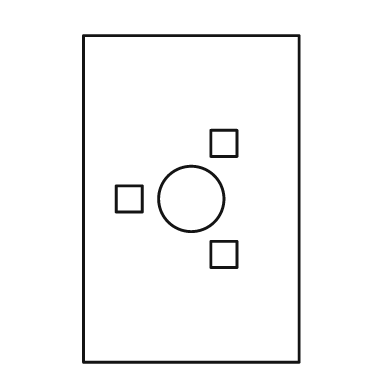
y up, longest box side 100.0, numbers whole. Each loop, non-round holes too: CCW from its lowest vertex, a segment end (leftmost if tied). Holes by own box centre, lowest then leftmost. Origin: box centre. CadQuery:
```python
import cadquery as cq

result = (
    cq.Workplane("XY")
    .moveTo(-33.0, -50.0)
    .lineTo(33.0, -50.0)
    .lineTo(33.0, 50.0)
    .lineTo(-33.0, 50.0)
    .close()
    .moveTo(6.0, -21.0)
    .lineTo(14.0, -21.0)
    .lineTo(14.0, -13.0)
    .lineTo(6.0, -13.0)
    .close()
    .moveTo(-23.0, -4.0)
    .lineTo(-15.0, -4.0)
    .lineTo(-15.0, 4.0)
    .lineTo(-23.0, 4.0)
    .close()
    .moveTo(0.0, 0.0)
    .circle(10.0)
    .moveTo(6.0, 13.0)
    .lineTo(14.0, 13.0)
    .lineTo(14.0, 21.0)
    .lineTo(6.0, 21.0)
    .close()
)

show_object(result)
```